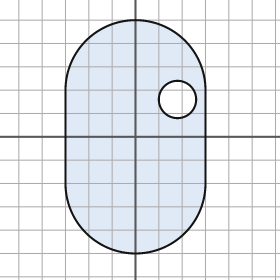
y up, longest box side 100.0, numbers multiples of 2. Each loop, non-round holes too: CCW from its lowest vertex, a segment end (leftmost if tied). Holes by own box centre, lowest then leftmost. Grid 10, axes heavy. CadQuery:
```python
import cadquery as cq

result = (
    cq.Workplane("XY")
    .moveTo(-30.0, -20.0)
    .threePointArc((0.0, -50.0), (30.0, -20.0))
    .lineTo(30.0, 20.0)
    .threePointArc((0.0, 50.0), (-30.0, 20.0))
    .close()
    .moveTo(18.0, 16.0)
    .circle(8.0)
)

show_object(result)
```